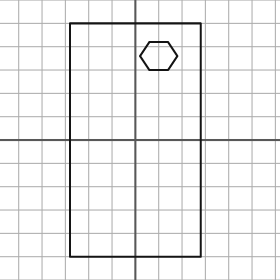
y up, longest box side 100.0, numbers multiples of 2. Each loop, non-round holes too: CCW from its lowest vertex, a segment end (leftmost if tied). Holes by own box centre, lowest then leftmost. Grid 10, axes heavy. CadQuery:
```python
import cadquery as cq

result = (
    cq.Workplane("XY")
    .moveTo(-28.0, -50.0)
    .lineTo(28.0, -50.0)
    .lineTo(28.0, 50.0)
    .lineTo(-28.0, 50.0)
    .close()
    .moveTo(6.0, 30.0)
    .lineTo(14.0, 30.0)
    .lineTo(18.0, 36.0)
    .lineTo(14.0, 42.0)
    .lineTo(6.0, 42.0)
    .lineTo(2.0, 36.0)
    .close()
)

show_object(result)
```